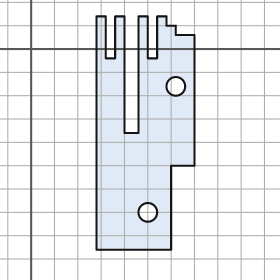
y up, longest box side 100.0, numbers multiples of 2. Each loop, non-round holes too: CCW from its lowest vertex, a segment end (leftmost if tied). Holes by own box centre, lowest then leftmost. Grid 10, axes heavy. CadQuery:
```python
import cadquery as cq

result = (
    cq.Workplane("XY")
    .moveTo(28.0, -86.0)
    .lineTo(60.0, -86.0)
    .lineTo(60.0, -50.0)
    .lineTo(70.0, -50.0)
    .lineTo(70.0, 6.0)
    .lineTo(62.0, 6.0)
    .lineTo(62.0, 10.0)
    .lineTo(58.0, 10.0)
    .lineTo(58.0, 14.0)
    .lineTo(54.0, 14.0)
    .lineTo(54.0, -4.0)
    .lineTo(50.0, -4.0)
    .lineTo(50.0, 14.0)
    .lineTo(46.0, 14.0)
    .lineTo(46.0, -36.0)
    .lineTo(40.0, -36.0)
    .lineTo(40.0, 14.0)
    .lineTo(36.0, 14.0)
    .lineTo(36.0, -4.0)
    .lineTo(32.0, -4.0)
    .lineTo(32.0, 14.0)
    .lineTo(28.0, 14.0)
    .close()
    .moveTo(50.0, -70.0)
    .circle(4.0)
    .moveTo(62.0, -16.0)
    .circle(4.0)
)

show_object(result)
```